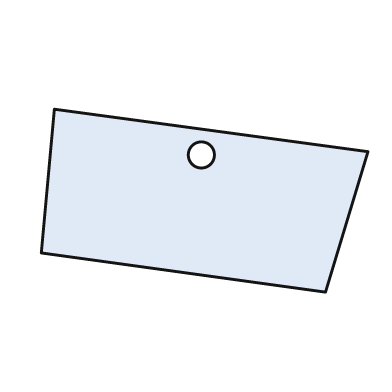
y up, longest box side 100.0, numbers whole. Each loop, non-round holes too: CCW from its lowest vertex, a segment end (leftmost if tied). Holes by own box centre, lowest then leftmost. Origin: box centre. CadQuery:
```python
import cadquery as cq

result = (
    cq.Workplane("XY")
    .moveTo(37.0, -28.0)
    .lineTo(50.0, 15.0)
    .lineTo(-46.0, 28.0)
    .lineTo(-50.0, -16.0)
    .close()
    .moveTo(-1.0, 14.0)
    .circle(4.0)
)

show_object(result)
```